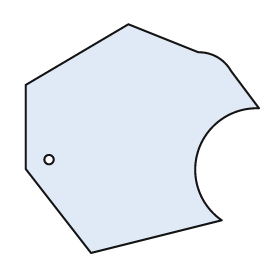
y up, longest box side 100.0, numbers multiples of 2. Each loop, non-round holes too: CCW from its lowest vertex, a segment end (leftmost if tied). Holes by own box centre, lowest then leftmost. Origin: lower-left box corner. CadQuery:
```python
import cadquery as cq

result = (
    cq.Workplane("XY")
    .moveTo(28.0, 0.0)
    .lineTo(84.0, 14.0)
    .threePointArc((74.0, 44.0), (100.0, 62.0))
    .lineTo(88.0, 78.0)
    .threePointArc((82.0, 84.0), (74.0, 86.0))
    .lineTo(44.0, 98.0)
    .lineTo(0.0, 72.0)
    .lineTo(0.0, 36.0)
    .close()
    .moveTo(10.0, 40.0)
    .circle(2.0)
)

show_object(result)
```